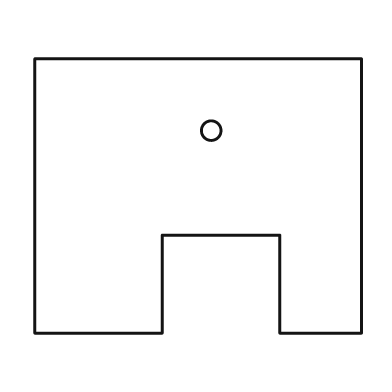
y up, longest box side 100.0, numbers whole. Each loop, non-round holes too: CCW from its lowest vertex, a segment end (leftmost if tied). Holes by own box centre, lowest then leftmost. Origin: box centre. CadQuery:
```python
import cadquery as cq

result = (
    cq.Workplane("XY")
    .moveTo(-50.0, -42.0)
    .lineTo(-11.0, -42.0)
    .lineTo(-11.0, -12.0)
    .lineTo(25.0, -12.0)
    .lineTo(25.0, -42.0)
    .lineTo(50.0, -42.0)
    .lineTo(50.0, 42.0)
    .lineTo(-50.0, 42.0)
    .close()
    .moveTo(4.0, 20.0)
    .circle(3.0)
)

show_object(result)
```